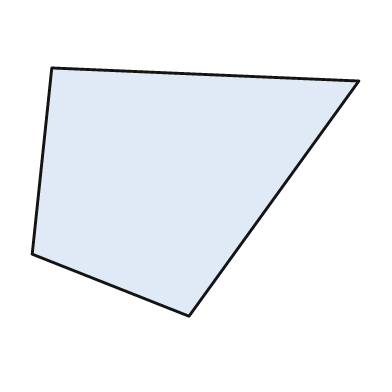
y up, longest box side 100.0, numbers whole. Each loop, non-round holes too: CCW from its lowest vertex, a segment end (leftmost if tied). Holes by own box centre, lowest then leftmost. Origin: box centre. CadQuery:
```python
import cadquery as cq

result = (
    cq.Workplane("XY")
    .moveTo(-2.0, -38.0)
    .lineTo(50.0, 34.0)
    .lineTo(-44.0, 38.0)
    .lineTo(-50.0, -19.0)
    .close()
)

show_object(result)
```